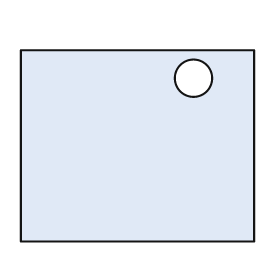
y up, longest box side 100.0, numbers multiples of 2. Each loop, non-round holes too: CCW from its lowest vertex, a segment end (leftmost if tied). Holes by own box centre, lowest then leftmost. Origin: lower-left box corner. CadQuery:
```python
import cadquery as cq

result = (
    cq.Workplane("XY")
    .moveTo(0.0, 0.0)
    .lineTo(100.0, 0.0)
    .lineTo(100.0, 82.0)
    .lineTo(0.0, 82.0)
    .close()
    .moveTo(74.0, 70.0)
    .circle(8.0)
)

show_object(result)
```